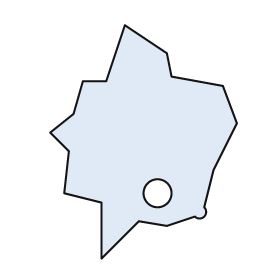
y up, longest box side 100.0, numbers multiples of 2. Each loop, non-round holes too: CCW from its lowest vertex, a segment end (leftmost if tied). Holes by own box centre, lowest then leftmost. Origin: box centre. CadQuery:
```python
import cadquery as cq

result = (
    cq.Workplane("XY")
    .moveTo(-18.0, -50.0)
    .lineTo(-2.0, -34.0)
    .lineTo(10.0, -36.0)
    .lineTo(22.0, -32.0)
    .threePointArc((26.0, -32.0), (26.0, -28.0))
    .lineTo(30.0, -12.0)
    .lineTo(40.0, 8.0)
    .lineTo(34.0, 24.0)
    .lineTo(12.0, 28.0)
    .lineTo(10.0, 38.0)
    .lineTo(-8.0, 50.0)
    .lineTo(-16.0, 26.0)
    .lineTo(-26.0, 26.0)
    .lineTo(-30.0, 12.0)
    .lineTo(-40.0, 4.0)
    .lineTo(-32.0, -4.0)
    .lineTo(-34.0, -22.0)
    .lineTo(-18.0, -26.0)
    .close()
    .moveTo(6.0, -22.0)
    .circle(6.0)
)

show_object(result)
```